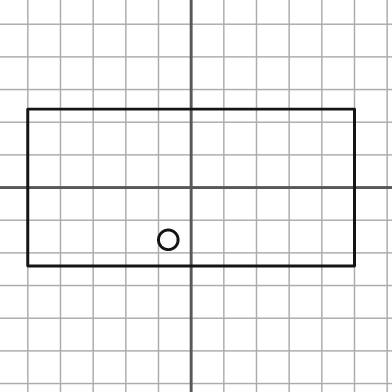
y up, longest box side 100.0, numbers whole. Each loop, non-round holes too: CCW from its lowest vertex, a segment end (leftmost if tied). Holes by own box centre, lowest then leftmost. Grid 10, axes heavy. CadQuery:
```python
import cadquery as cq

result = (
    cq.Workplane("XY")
    .moveTo(-50.0, -24.0)
    .lineTo(50.0, -24.0)
    .lineTo(50.0, 24.0)
    .lineTo(-50.0, 24.0)
    .close()
    .moveTo(-7.0, -16.0)
    .circle(3.0)
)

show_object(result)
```